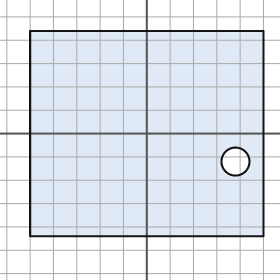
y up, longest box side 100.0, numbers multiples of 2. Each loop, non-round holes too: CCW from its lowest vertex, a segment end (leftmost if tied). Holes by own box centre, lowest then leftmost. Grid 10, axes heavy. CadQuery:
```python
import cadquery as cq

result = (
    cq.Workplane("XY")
    .moveTo(-50.0, -44.0)
    .lineTo(50.0, -44.0)
    .lineTo(50.0, 44.0)
    .lineTo(-50.0, 44.0)
    .close()
    .moveTo(38.0, -12.0)
    .circle(6.0)
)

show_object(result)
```